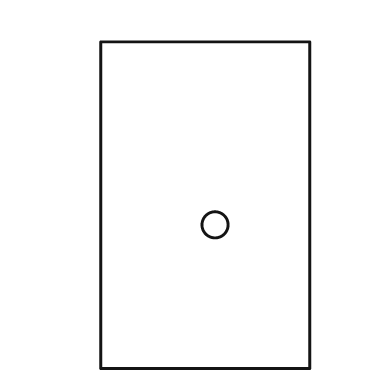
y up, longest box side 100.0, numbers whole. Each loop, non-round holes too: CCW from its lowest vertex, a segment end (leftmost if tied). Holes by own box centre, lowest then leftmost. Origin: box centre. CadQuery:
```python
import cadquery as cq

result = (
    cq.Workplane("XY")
    .moveTo(-32.0, -50.0)
    .lineTo(32.0, -50.0)
    .lineTo(32.0, 50.0)
    .lineTo(-32.0, 50.0)
    .close()
    .moveTo(3.0, -6.0)
    .circle(4.0)
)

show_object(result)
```